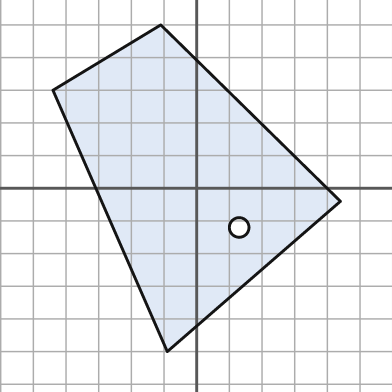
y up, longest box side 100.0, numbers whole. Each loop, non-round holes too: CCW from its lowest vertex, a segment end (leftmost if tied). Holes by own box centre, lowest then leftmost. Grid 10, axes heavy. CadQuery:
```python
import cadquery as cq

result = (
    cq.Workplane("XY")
    .moveTo(-9.0, -50.0)
    .lineTo(44.0, -4.0)
    .lineTo(-11.0, 50.0)
    .lineTo(-44.0, 30.0)
    .close()
    .moveTo(13.0, -12.0)
    .circle(3.0)
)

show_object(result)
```